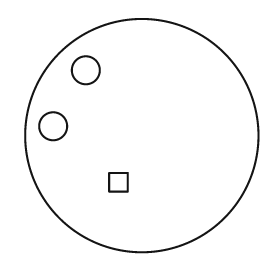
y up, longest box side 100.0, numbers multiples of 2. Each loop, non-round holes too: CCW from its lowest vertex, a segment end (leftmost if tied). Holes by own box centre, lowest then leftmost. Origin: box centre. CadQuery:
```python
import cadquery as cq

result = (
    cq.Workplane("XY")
    .moveTo(0.0, 0.0)
    .circle(50.0)
    .moveTo(-14.0, -24.0)
    .lineTo(-6.0, -24.0)
    .lineTo(-6.0, -16.0)
    .lineTo(-14.0, -16.0)
    .close()
    .moveTo(-38.0, 4.0)
    .circle(6.0)
    .moveTo(-24.0, 28.0)
    .circle(6.0)
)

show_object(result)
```